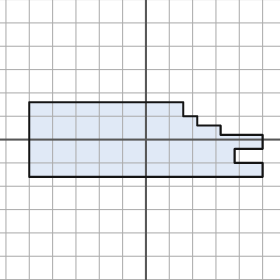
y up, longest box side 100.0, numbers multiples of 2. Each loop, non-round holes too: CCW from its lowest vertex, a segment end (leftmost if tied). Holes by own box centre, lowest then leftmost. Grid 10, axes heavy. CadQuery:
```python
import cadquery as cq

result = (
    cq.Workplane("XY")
    .moveTo(-50.0, -16.0)
    .lineTo(50.0, -16.0)
    .lineTo(50.0, -10.0)
    .lineTo(38.0, -10.0)
    .lineTo(38.0, -4.0)
    .lineTo(50.0, -4.0)
    .lineTo(50.0, 2.0)
    .lineTo(32.0, 2.0)
    .lineTo(32.0, 6.0)
    .lineTo(22.0, 6.0)
    .lineTo(22.0, 10.0)
    .lineTo(16.0, 10.0)
    .lineTo(16.0, 16.0)
    .lineTo(-50.0, 16.0)
    .close()
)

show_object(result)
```